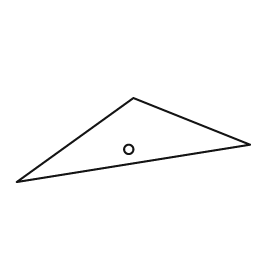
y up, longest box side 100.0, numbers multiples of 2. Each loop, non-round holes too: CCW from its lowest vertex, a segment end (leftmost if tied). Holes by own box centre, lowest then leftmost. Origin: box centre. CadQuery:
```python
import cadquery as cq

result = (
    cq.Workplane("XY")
    .moveTo(-50.0, -18.0)
    .lineTo(50.0, -2.0)
    .lineTo(0.0, 18.0)
    .close()
    .moveTo(-2.0, -4.0)
    .circle(2.0)
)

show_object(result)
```